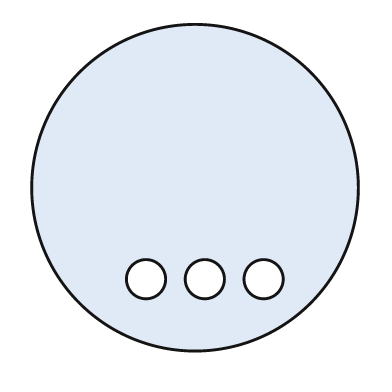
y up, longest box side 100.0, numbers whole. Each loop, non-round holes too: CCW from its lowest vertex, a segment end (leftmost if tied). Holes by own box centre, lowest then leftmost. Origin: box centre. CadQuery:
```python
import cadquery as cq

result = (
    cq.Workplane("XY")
    .moveTo(0.0, 0.0)
    .circle(50.0)
    .moveTo(-15.0, -28.0)
    .circle(6.0)
    .moveTo(3.0, -28.0)
    .circle(6.0)
    .moveTo(21.0, -28.0)
    .circle(6.0)
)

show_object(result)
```